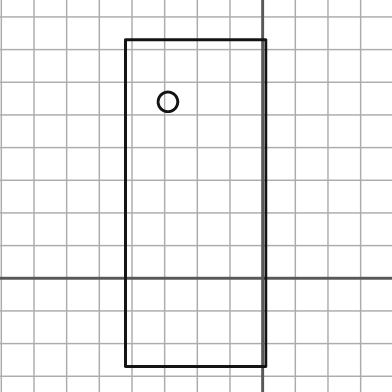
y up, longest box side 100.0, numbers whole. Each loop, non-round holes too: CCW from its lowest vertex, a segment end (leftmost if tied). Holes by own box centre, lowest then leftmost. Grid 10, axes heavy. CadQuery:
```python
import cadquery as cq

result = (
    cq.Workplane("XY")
    .moveTo(-42.0, -27.0)
    .lineTo(1.0, -27.0)
    .lineTo(1.0, 73.0)
    .lineTo(-42.0, 73.0)
    .close()
    .moveTo(-29.0, 54.0)
    .circle(3.0)
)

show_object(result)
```